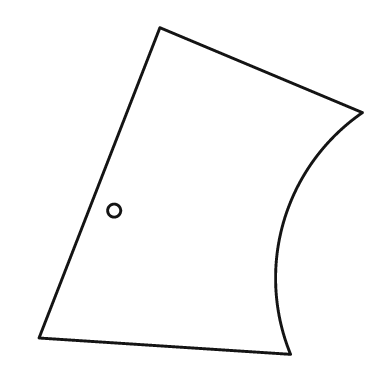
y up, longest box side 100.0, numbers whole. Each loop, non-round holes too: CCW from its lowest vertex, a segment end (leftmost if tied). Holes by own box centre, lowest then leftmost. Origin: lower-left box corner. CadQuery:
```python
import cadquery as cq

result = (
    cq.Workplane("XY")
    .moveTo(77.0, 0.0)
    .threePointArc((75.0, 41.0), (99.0, 74.0))
    .lineTo(37.0, 100.0)
    .lineTo(0.0, 5.0)
    .close()
    .moveTo(23.0, 44.0)
    .circle(2.0)
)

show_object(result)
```